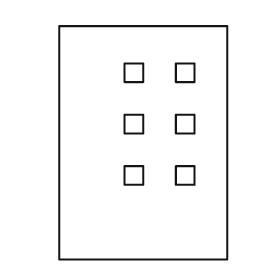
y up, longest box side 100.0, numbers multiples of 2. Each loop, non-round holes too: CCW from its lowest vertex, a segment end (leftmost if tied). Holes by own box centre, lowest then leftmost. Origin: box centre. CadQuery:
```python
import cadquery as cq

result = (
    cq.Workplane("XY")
    .moveTo(-36.0, -50.0)
    .lineTo(36.0, -50.0)
    .lineTo(36.0, 50.0)
    .lineTo(-36.0, 50.0)
    .close()
    .moveTo(-8.0, -18.0)
    .lineTo(0.0, -18.0)
    .lineTo(0.0, -10.0)
    .lineTo(-8.0, -10.0)
    .close()
    .moveTo(14.0, -18.0)
    .lineTo(22.0, -18.0)
    .lineTo(22.0, -10.0)
    .lineTo(14.0, -10.0)
    .close()
    .moveTo(-8.0, 4.0)
    .lineTo(0.0, 4.0)
    .lineTo(0.0, 12.0)
    .lineTo(-8.0, 12.0)
    .close()
    .moveTo(14.0, 4.0)
    .lineTo(22.0, 4.0)
    .lineTo(22.0, 12.0)
    .lineTo(14.0, 12.0)
    .close()
    .moveTo(-8.0, 26.0)
    .lineTo(0.0, 26.0)
    .lineTo(0.0, 34.0)
    .lineTo(-8.0, 34.0)
    .close()
    .moveTo(14.0, 26.0)
    .lineTo(22.0, 26.0)
    .lineTo(22.0, 34.0)
    .lineTo(14.0, 34.0)
    .close()
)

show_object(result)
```